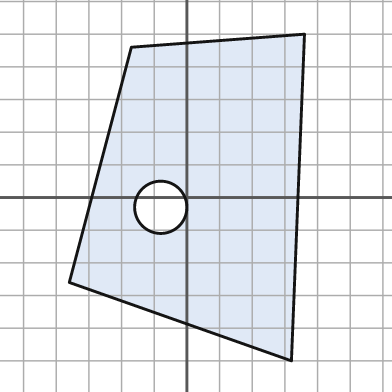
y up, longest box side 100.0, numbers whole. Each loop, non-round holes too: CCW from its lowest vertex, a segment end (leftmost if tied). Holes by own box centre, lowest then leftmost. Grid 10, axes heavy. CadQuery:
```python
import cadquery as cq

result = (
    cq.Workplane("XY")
    .moveTo(32.0, -50.0)
    .lineTo(36.0, 50.0)
    .lineTo(-17.0, 46.0)
    .lineTo(-36.0, -26.0)
    .close()
    .moveTo(-8.0, -3.0)
    .circle(8.0)
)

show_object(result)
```